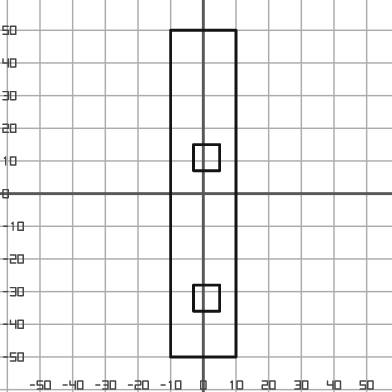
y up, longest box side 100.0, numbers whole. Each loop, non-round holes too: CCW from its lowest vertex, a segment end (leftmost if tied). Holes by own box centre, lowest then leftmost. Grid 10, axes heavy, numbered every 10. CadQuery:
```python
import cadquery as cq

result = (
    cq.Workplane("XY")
    .moveTo(-10.0, -50.0)
    .lineTo(10.0, -50.0)
    .lineTo(10.0, 50.0)
    .lineTo(-10.0, 50.0)
    .close()
    .moveTo(-3.0, -36.0)
    .lineTo(5.0, -36.0)
    .lineTo(5.0, -28.0)
    .lineTo(-3.0, -28.0)
    .close()
    .moveTo(-3.0, 7.0)
    .lineTo(5.0, 7.0)
    .lineTo(5.0, 15.0)
    .lineTo(-3.0, 15.0)
    .close()
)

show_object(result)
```